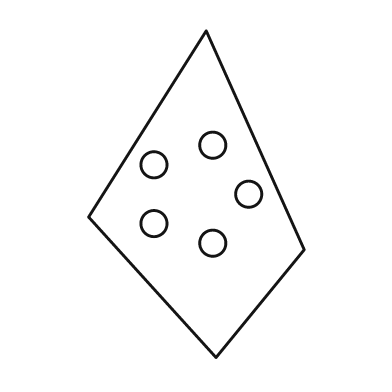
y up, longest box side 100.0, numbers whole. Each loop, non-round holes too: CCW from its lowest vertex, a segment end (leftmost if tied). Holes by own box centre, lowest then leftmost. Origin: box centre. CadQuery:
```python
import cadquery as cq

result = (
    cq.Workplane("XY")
    .moveTo(6.0, -50.0)
    .lineTo(33.0, -17.0)
    .lineTo(3.0, 50.0)
    .lineTo(-33.0, -7.0)
    .close()
    .moveTo(5.0, -15.0)
    .circle(4.0)
    .moveTo(-13.0, -9.0)
    .circle(4.0)
    .moveTo(16.0, 0.0)
    .circle(4.0)
    .moveTo(-13.0, 9.0)
    .circle(4.0)
    .moveTo(5.0, 15.0)
    .circle(4.0)
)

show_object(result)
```